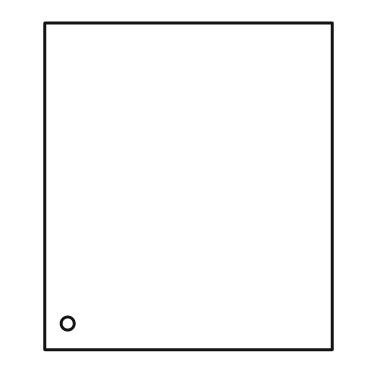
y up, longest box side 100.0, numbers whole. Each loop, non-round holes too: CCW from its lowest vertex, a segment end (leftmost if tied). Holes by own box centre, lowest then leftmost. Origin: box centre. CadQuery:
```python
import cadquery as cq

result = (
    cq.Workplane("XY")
    .moveTo(-44.0, -50.0)
    .lineTo(44.0, -50.0)
    .lineTo(44.0, 50.0)
    .lineTo(-44.0, 50.0)
    .close()
    .moveTo(-37.0, -42.0)
    .circle(2.0)
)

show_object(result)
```